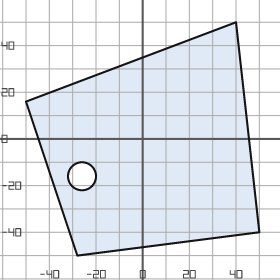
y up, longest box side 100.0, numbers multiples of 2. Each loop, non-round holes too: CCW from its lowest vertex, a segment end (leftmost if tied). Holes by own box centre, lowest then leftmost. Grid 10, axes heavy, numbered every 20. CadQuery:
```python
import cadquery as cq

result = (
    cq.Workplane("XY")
    .moveTo(-28.0, -50.0)
    .lineTo(50.0, -40.0)
    .lineTo(40.0, 50.0)
    .lineTo(-50.0, 16.0)
    .close()
    .moveTo(-26.0, -16.0)
    .circle(6.0)
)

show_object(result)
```